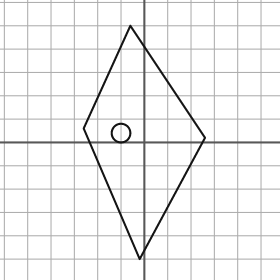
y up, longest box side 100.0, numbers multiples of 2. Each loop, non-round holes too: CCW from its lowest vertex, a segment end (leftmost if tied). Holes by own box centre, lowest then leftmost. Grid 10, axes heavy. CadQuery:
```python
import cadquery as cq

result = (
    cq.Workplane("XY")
    .moveTo(-2.0, -50.0)
    .lineTo(26.0, 2.0)
    .lineTo(-6.0, 50.0)
    .lineTo(-26.0, 6.0)
    .close()
    .moveTo(-10.0, 4.0)
    .circle(4.0)
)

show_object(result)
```